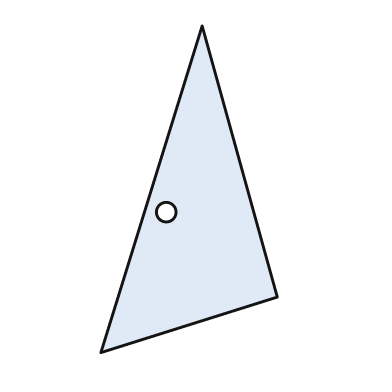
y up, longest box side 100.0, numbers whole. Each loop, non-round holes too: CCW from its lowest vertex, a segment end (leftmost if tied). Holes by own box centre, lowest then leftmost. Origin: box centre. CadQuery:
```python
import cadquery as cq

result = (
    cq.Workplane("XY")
    .moveTo(-27.0, -50.0)
    .lineTo(27.0, -33.0)
    .lineTo(4.0, 50.0)
    .close()
    .moveTo(-7.0, -7.0)
    .circle(3.0)
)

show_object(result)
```